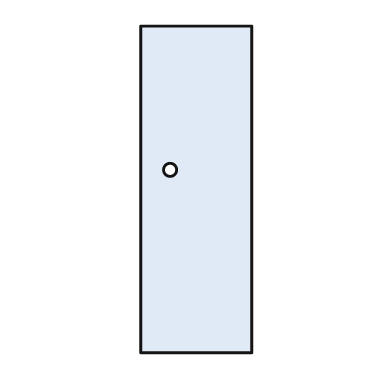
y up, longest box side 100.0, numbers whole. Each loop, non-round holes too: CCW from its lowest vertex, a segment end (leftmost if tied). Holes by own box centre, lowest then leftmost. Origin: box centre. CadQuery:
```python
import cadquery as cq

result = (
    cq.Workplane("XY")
    .moveTo(-17.0, -50.0)
    .lineTo(17.0, -50.0)
    .lineTo(17.0, 50.0)
    .lineTo(-17.0, 50.0)
    .close()
    .moveTo(-8.0, 6.0)
    .circle(2.0)
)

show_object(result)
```